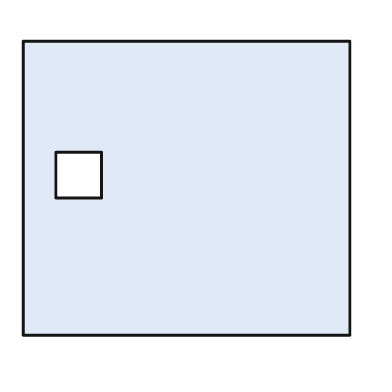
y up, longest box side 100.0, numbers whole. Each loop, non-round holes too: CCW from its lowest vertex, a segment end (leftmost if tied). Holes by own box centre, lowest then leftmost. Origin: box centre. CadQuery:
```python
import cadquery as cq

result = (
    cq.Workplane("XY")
    .moveTo(-50.0, -45.0)
    .lineTo(50.0, -45.0)
    .lineTo(50.0, 45.0)
    .lineTo(-50.0, 45.0)
    .close()
    .moveTo(-40.0, -3.0)
    .lineTo(-26.0, -3.0)
    .lineTo(-26.0, 11.0)
    .lineTo(-40.0, 11.0)
    .close()
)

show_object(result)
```